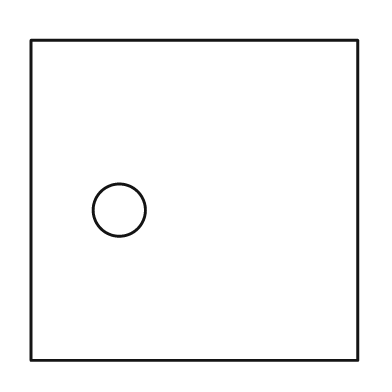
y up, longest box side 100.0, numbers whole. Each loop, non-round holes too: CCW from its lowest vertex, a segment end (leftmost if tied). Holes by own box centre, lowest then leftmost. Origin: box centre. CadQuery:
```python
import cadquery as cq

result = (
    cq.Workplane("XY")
    .moveTo(-50.0, -49.0)
    .lineTo(50.0, -49.0)
    .lineTo(50.0, 49.0)
    .lineTo(-50.0, 49.0)
    .close()
    .moveTo(-23.0, -3.0)
    .circle(8.0)
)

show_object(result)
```